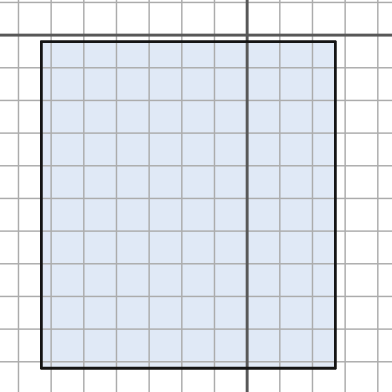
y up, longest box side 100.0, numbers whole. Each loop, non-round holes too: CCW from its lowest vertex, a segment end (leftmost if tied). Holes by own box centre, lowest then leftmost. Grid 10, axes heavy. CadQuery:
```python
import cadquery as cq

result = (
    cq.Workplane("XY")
    .moveTo(-63.0, -102.0)
    .lineTo(27.0, -102.0)
    .lineTo(27.0, -2.0)
    .lineTo(-63.0, -2.0)
    .close()
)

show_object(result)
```